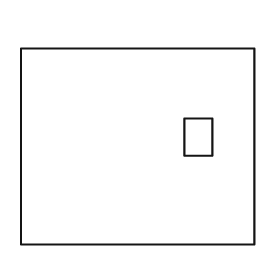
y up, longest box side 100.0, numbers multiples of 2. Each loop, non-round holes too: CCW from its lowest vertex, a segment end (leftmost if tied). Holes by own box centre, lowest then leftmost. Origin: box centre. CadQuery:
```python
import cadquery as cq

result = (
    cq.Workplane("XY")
    .moveTo(-50.0, -42.0)
    .lineTo(50.0, -42.0)
    .lineTo(50.0, 42.0)
    .lineTo(-50.0, 42.0)
    .close()
    .moveTo(20.0, -4.0)
    .lineTo(32.0, -4.0)
    .lineTo(32.0, 12.0)
    .lineTo(20.0, 12.0)
    .close()
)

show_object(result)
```